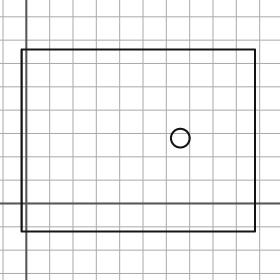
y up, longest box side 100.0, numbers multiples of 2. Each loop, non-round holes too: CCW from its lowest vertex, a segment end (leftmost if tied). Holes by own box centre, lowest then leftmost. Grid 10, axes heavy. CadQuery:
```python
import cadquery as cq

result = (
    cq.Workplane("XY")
    .moveTo(-2.0, -12.0)
    .lineTo(98.0, -12.0)
    .lineTo(98.0, 66.0)
    .lineTo(-2.0, 66.0)
    .close()
    .moveTo(66.0, 28.0)
    .circle(4.0)
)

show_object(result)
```